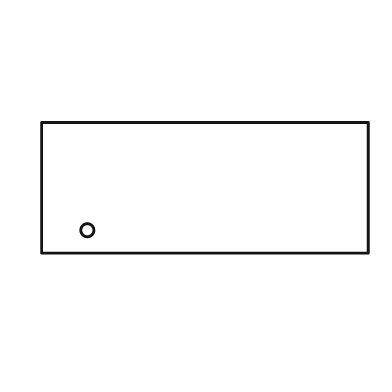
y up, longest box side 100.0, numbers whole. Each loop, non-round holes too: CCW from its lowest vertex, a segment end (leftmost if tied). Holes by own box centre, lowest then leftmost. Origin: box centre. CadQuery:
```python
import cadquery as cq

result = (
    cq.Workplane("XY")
    .moveTo(-50.0, -20.0)
    .lineTo(50.0, -20.0)
    .lineTo(50.0, 20.0)
    .lineTo(-50.0, 20.0)
    .close()
    .moveTo(-36.0, -13.0)
    .circle(2.0)
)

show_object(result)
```